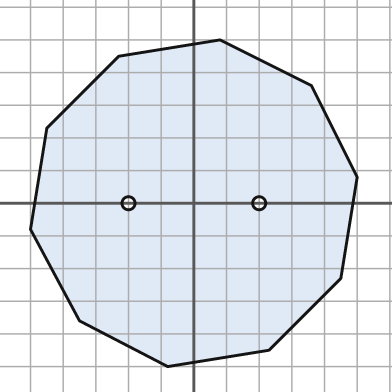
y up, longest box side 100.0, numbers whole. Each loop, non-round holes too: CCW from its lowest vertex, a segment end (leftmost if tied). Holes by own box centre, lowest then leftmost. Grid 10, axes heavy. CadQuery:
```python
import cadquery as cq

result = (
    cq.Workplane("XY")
    .moveTo(-8.0, -50.0)
    .lineTo(23.0, -45.0)
    .lineTo(45.0, -23.0)
    .lineTo(50.0, 8.0)
    .lineTo(36.0, 36.0)
    .lineTo(8.0, 50.0)
    .lineTo(-23.0, 45.0)
    .lineTo(-45.0, 23.0)
    .lineTo(-50.0, -8.0)
    .lineTo(-35.0, -36.0)
    .close()
    .moveTo(-20.0, 0.0)
    .circle(2.0)
    .moveTo(20.0, 0.0)
    .circle(2.0)
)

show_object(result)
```